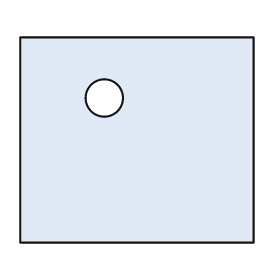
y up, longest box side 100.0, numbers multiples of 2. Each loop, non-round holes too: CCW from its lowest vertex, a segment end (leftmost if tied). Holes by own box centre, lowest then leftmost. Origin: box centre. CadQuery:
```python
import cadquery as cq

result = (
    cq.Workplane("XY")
    .moveTo(-50.0, -44.0)
    .lineTo(50.0, -44.0)
    .lineTo(50.0, 44.0)
    .lineTo(-50.0, 44.0)
    .close()
    .moveTo(-14.0, 18.0)
    .circle(8.0)
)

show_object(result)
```